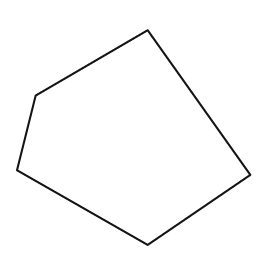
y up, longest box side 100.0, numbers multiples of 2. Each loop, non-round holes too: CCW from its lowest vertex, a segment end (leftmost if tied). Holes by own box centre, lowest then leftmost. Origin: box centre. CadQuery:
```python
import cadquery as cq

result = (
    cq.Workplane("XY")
    .moveTo(6.0, -46.0)
    .lineTo(50.0, -16.0)
    .lineTo(6.0, 46.0)
    .lineTo(-42.0, 18.0)
    .lineTo(-50.0, -14.0)
    .close()
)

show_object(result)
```